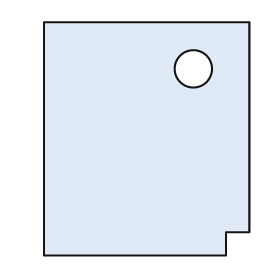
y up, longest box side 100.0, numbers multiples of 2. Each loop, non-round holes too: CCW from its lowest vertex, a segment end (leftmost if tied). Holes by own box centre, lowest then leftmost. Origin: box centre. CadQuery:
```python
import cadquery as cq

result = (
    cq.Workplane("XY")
    .moveTo(-44.0, -50.0)
    .lineTo(34.0, -50.0)
    .lineTo(34.0, -40.0)
    .lineTo(44.0, -40.0)
    .lineTo(44.0, 50.0)
    .lineTo(-44.0, 50.0)
    .close()
    .moveTo(20.0, 30.0)
    .circle(8.0)
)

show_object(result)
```